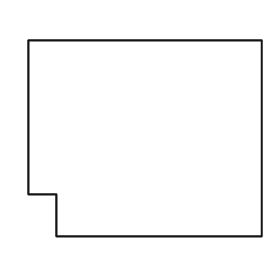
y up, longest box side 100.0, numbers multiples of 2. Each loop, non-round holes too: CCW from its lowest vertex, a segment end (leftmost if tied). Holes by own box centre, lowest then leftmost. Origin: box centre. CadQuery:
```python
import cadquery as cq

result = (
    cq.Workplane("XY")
    .moveTo(-38.0, -42.0)
    .lineTo(50.0, -42.0)
    .lineTo(50.0, 42.0)
    .lineTo(-50.0, 42.0)
    .lineTo(-50.0, -24.0)
    .lineTo(-38.0, -24.0)
    .close()
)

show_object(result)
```